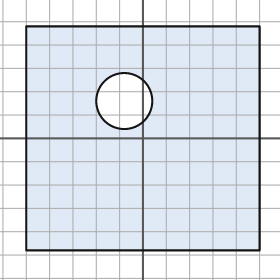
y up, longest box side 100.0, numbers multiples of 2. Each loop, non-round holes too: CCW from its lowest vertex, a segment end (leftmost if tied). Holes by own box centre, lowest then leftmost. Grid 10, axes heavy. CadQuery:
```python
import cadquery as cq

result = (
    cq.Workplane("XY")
    .moveTo(-50.0, -48.0)
    .lineTo(50.0, -48.0)
    .lineTo(50.0, 48.0)
    .lineTo(-50.0, 48.0)
    .close()
    .moveTo(-8.0, 16.0)
    .circle(12.0)
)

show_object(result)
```